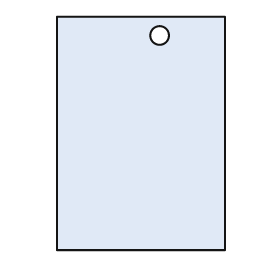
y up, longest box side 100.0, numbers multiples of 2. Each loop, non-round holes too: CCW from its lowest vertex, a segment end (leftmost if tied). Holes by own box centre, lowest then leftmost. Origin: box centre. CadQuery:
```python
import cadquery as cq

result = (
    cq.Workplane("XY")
    .moveTo(-36.0, -50.0)
    .lineTo(36.0, -50.0)
    .lineTo(36.0, 50.0)
    .lineTo(-36.0, 50.0)
    .close()
    .moveTo(8.0, 42.0)
    .circle(4.0)
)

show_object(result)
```